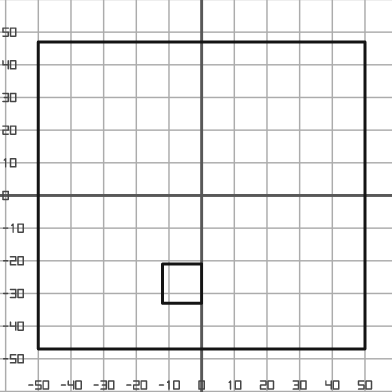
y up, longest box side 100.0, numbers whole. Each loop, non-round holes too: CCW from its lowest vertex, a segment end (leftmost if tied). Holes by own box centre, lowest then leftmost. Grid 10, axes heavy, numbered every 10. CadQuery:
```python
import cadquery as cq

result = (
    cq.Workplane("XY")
    .moveTo(-50.0, -47.0)
    .lineTo(50.0, -47.0)
    .lineTo(50.0, 47.0)
    .lineTo(-50.0, 47.0)
    .close()
    .moveTo(-12.0, -33.0)
    .lineTo(0.0, -33.0)
    .lineTo(0.0, -21.0)
    .lineTo(-12.0, -21.0)
    .close()
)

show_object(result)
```